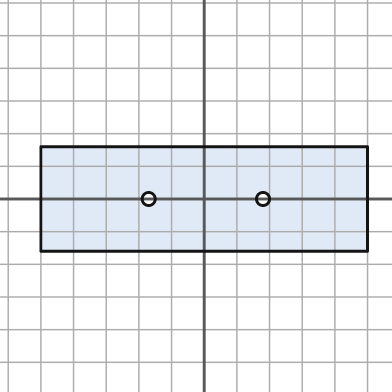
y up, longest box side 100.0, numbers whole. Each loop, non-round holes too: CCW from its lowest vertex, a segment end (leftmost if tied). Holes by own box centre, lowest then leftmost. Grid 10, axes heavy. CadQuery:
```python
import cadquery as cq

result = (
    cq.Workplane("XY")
    .moveTo(-50.0, -16.0)
    .lineTo(50.0, -16.0)
    .lineTo(50.0, 16.0)
    .lineTo(-50.0, 16.0)
    .close()
    .moveTo(-17.0, 0.0)
    .circle(2.0)
    .moveTo(18.0, 0.0)
    .circle(2.0)
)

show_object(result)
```